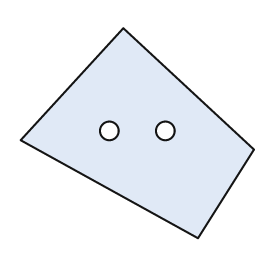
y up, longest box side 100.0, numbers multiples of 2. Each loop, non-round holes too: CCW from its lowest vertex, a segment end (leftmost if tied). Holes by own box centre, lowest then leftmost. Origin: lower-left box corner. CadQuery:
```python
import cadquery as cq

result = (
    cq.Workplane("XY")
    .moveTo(76.0, 0.0)
    .lineTo(100.0, 38.0)
    .lineTo(44.0, 90.0)
    .lineTo(0.0, 42.0)
    .close()
    .moveTo(38.0, 46.0)
    .circle(4.0)
    .moveTo(62.0, 46.0)
    .circle(4.0)
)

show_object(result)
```